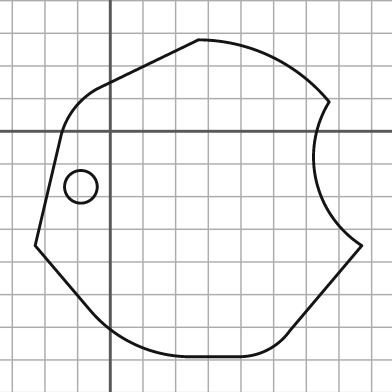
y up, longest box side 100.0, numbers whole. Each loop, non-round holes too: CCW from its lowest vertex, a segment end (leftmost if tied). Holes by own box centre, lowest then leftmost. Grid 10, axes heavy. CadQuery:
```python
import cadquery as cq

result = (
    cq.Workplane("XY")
    .moveTo(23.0, -69.0)
    .lineTo(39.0, -69.0)
    .threePointArc((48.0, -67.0), (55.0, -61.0))
    .lineTo(77.0, -35.0)
    .threePointArc((63.0, -15.0), (67.0, 9.0))
    .threePointArc((49.0, 23.0), (27.0, 28.0))
    .lineTo(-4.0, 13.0)
    .threePointArc((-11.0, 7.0), (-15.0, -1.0))
    .lineTo(-23.0, -35.0)
    .lineTo(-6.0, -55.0)
    .threePointArc((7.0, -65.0), (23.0, -69.0))
    .close()
    .moveTo(-9.0, -17.0)
    .circle(5.0)
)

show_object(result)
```